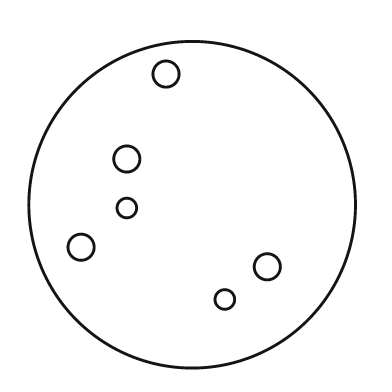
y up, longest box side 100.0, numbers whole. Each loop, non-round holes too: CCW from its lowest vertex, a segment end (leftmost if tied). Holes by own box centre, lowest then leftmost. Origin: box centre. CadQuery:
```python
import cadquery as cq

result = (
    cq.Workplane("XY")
    .moveTo(0.0, 0.0)
    .circle(50.0)
    .moveTo(10.0, -29.0)
    .circle(3.0)
    .moveTo(23.0, -19.0)
    .circle(4.0)
    .moveTo(-34.0, -13.0)
    .circle(4.0)
    .moveTo(-20.0, -1.0)
    .circle(3.0)
    .moveTo(-20.0, 14.0)
    .circle(4.0)
    .moveTo(-8.0, 40.0)
    .circle(4.0)
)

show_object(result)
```